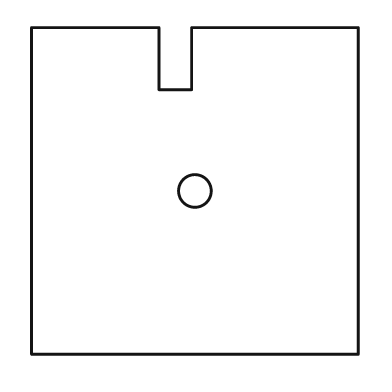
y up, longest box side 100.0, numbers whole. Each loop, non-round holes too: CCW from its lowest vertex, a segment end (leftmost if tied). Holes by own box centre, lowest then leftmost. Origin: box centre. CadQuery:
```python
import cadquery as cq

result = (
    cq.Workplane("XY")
    .moveTo(-50.0, -50.0)
    .lineTo(50.0, -50.0)
    .lineTo(50.0, 50.0)
    .lineTo(-1.0, 50.0)
    .lineTo(-1.0, 31.0)
    .lineTo(-11.0, 31.0)
    .lineTo(-11.0, 50.0)
    .lineTo(-50.0, 50.0)
    .close()
    .moveTo(0.0, 0.0)
    .circle(5.0)
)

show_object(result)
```